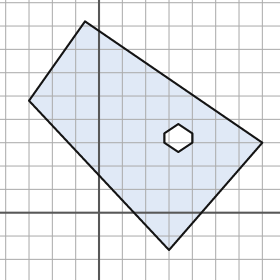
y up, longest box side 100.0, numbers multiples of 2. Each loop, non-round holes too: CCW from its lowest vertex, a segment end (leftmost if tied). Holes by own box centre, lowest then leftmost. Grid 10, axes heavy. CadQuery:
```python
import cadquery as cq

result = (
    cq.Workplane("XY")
    .moveTo(30.0, -16.0)
    .lineTo(70.0, 30.0)
    .lineTo(-6.0, 82.0)
    .lineTo(-30.0, 48.0)
    .close()
    .moveTo(34.0, 26.0)
    .lineTo(40.0, 30.0)
    .lineTo(40.0, 34.0)
    .lineTo(34.0, 38.0)
    .lineTo(28.0, 34.0)
    .lineTo(28.0, 30.0)
    .close()
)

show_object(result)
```